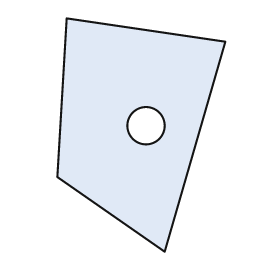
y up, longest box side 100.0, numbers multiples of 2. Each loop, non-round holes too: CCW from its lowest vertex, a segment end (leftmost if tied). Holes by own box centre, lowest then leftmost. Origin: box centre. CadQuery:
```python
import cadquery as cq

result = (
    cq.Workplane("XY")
    .moveTo(10.0, -50.0)
    .lineTo(36.0, 40.0)
    .lineTo(-32.0, 50.0)
    .lineTo(-36.0, -18.0)
    .close()
    .moveTo(2.0, 4.0)
    .circle(8.0)
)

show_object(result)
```